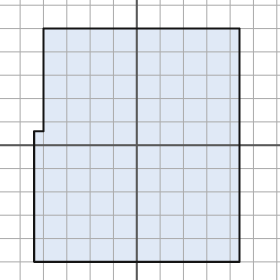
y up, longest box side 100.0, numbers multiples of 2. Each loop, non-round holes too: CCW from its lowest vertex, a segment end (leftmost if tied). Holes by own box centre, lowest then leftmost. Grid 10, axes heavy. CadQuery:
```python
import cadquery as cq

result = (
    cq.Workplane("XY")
    .moveTo(-44.0, -50.0)
    .lineTo(44.0, -50.0)
    .lineTo(44.0, 50.0)
    .lineTo(-40.0, 50.0)
    .lineTo(-40.0, 6.0)
    .lineTo(-44.0, 6.0)
    .close()
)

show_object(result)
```